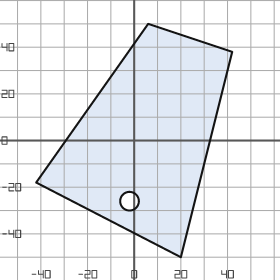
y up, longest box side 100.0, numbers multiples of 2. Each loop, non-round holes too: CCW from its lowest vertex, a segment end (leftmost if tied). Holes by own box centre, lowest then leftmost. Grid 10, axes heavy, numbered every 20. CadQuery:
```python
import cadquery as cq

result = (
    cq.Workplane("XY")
    .moveTo(20.0, -50.0)
    .lineTo(42.0, 38.0)
    .lineTo(6.0, 50.0)
    .lineTo(-42.0, -18.0)
    .close()
    .moveTo(-2.0, -26.0)
    .circle(4.0)
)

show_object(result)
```